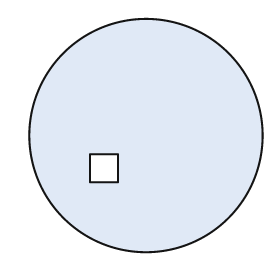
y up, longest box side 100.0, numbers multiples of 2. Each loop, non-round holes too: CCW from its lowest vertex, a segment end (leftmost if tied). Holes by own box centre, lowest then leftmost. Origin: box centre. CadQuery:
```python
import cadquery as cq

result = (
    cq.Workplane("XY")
    .moveTo(0.0, 0.0)
    .circle(50.0)
    .moveTo(-24.0, -20.0)
    .lineTo(-12.0, -20.0)
    .lineTo(-12.0, -8.0)
    .lineTo(-24.0, -8.0)
    .close()
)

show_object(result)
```